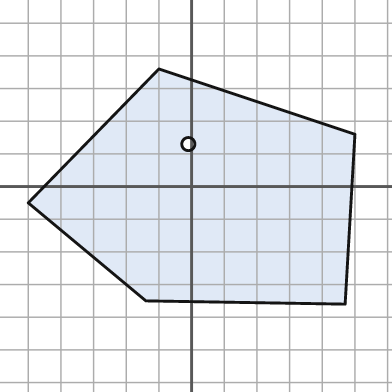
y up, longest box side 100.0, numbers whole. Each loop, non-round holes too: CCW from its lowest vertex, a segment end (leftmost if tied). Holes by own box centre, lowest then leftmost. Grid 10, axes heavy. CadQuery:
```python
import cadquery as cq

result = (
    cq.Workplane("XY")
    .moveTo(47.0, -36.0)
    .lineTo(50.0, 16.0)
    .lineTo(-10.0, 36.0)
    .lineTo(-50.0, -5.0)
    .lineTo(-14.0, -35.0)
    .close()
    .moveTo(-1.0, 13.0)
    .circle(2.0)
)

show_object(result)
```